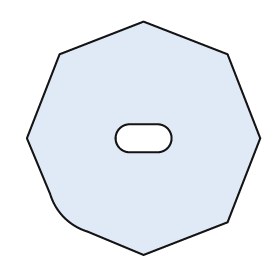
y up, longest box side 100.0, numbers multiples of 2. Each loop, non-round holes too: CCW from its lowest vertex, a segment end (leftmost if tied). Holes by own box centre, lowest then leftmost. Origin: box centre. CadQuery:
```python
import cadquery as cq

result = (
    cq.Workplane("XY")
    .moveTo(0.0, -50.0)
    .lineTo(36.0, -36.0)
    .lineTo(50.0, 0.0)
    .lineTo(36.0, 36.0)
    .lineTo(0.0, 50.0)
    .lineTo(-36.0, 36.0)
    .lineTo(-50.0, 0.0)
    .lineTo(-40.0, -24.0)
    .threePointArc((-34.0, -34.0), (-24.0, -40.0))
    .close()
    .moveTo(-6.0, -6.0)
    .lineTo(6.0, -6.0)
    .threePointArc((12.0, 0.0), (6.0, 6.0))
    .lineTo(-6.0, 6.0)
    .threePointArc((-12.0, 0.0), (-6.0, -6.0))
    .close()
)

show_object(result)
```